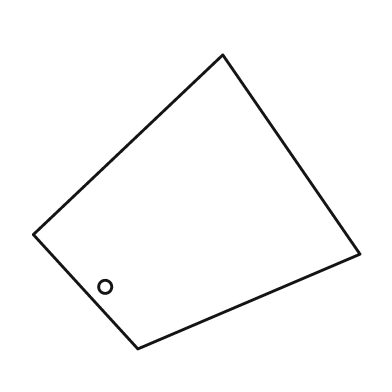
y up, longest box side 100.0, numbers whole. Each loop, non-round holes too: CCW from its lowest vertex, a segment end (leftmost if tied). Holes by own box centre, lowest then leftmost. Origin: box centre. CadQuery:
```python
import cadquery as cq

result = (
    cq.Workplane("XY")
    .moveTo(-18.0, -45.0)
    .lineTo(50.0, -16.0)
    .lineTo(8.0, 45.0)
    .lineTo(-50.0, -10.0)
    .close()
    .moveTo(-28.0, -26.0)
    .circle(2.0)
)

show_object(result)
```